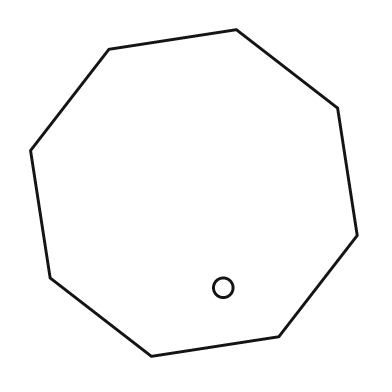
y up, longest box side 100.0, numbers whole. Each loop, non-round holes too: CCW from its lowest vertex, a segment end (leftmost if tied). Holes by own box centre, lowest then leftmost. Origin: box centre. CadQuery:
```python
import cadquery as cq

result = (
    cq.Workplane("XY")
    .moveTo(-13.0, -50.0)
    .lineTo(26.0, -44.0)
    .lineTo(50.0, -13.0)
    .lineTo(44.0, 26.0)
    .lineTo(13.0, 50.0)
    .lineTo(-26.0, 44.0)
    .lineTo(-50.0, 13.0)
    .lineTo(-44.0, -26.0)
    .close()
    .moveTo(9.0, -29.0)
    .circle(3.0)
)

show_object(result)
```